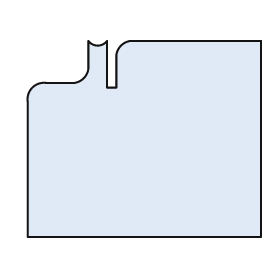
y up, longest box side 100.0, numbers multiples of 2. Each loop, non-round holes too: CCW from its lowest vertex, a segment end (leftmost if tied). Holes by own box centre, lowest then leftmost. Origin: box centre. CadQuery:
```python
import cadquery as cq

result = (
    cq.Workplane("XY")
    .moveTo(-50.0, -42.0)
    .lineTo(50.0, -42.0)
    .lineTo(50.0, 42.0)
    .lineTo(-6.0, 42.0)
    .threePointArc((-10.0, 40.0), (-12.0, 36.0))
    .lineTo(-12.0, 22.0)
    .lineTo(-16.0, 22.0)
    .lineTo(-16.0, 42.0)
    .threePointArc((-20.0, 40.0), (-24.0, 42.0))
    .lineTo(-24.0, 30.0)
    .threePointArc((-26.0, 26.0), (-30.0, 24.0))
    .lineTo(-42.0, 24.0)
    .threePointArc((-48.0, 22.0), (-50.0, 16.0))
    .close()
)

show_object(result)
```